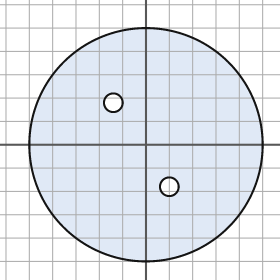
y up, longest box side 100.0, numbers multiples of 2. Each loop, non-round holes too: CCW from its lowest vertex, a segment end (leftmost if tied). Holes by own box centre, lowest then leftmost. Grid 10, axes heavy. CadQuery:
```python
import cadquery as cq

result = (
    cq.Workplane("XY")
    .moveTo(0.0, 0.0)
    .circle(50.0)
    .moveTo(10.0, -18.0)
    .circle(4.0)
    .moveTo(-14.0, 18.0)
    .circle(4.0)
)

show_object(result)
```